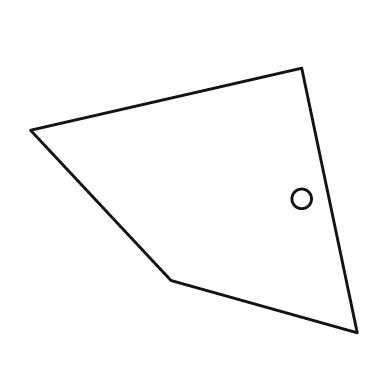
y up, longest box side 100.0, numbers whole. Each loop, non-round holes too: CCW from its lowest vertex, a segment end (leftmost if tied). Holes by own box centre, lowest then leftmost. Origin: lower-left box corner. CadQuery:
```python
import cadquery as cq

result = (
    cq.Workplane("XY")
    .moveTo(100.0, 0.0)
    .lineTo(83.0, 81.0)
    .lineTo(0.0, 62.0)
    .lineTo(43.0, 16.0)
    .close()
    .moveTo(83.0, 41.0)
    .circle(3.0)
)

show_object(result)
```